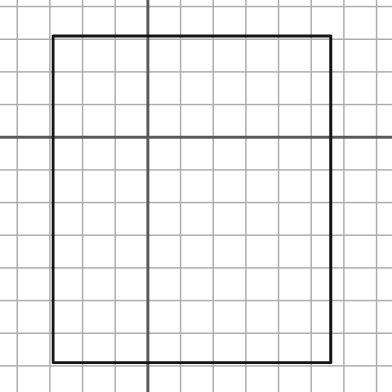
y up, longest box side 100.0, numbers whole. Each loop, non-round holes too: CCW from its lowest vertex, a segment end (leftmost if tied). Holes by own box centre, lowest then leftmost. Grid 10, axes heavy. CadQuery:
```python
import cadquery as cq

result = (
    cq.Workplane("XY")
    .moveTo(-29.0, -69.0)
    .lineTo(56.0, -69.0)
    .lineTo(56.0, 31.0)
    .lineTo(-29.0, 31.0)
    .close()
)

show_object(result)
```